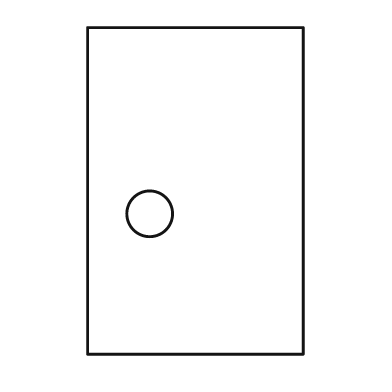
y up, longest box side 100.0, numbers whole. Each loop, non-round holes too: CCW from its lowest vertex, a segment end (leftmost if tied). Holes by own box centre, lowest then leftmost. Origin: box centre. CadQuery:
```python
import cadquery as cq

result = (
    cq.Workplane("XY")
    .moveTo(-33.0, -50.0)
    .lineTo(33.0, -50.0)
    .lineTo(33.0, 50.0)
    .lineTo(-33.0, 50.0)
    .close()
    .moveTo(-14.0, -7.0)
    .circle(7.0)
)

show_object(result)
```